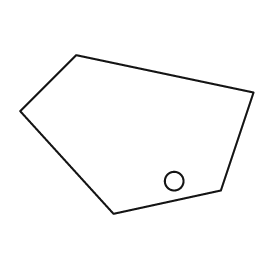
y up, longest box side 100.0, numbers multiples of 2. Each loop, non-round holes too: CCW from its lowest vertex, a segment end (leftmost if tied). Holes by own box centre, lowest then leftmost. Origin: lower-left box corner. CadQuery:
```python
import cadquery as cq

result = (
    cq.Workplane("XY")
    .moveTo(40.0, 0.0)
    .lineTo(86.0, 10.0)
    .lineTo(100.0, 52.0)
    .lineTo(24.0, 68.0)
    .lineTo(0.0, 44.0)
    .close()
    .moveTo(66.0, 14.0)
    .circle(4.0)
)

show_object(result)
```